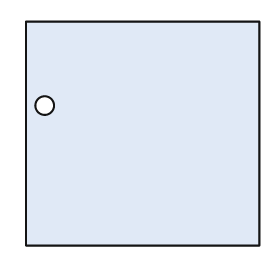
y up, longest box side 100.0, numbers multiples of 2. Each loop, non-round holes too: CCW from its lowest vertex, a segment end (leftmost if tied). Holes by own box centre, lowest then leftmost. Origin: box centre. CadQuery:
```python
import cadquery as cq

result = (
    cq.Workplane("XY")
    .moveTo(-50.0, -48.0)
    .lineTo(50.0, -48.0)
    .lineTo(50.0, 48.0)
    .lineTo(-50.0, 48.0)
    .close()
    .moveTo(-42.0, 12.0)
    .circle(4.0)
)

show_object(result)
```